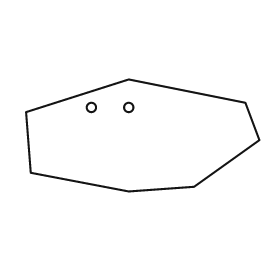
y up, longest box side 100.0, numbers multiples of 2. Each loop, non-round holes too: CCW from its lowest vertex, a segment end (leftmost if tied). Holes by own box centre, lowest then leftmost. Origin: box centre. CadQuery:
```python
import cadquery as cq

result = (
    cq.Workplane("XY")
    .moveTo(-6.0, -24.0)
    .lineTo(22.0, -22.0)
    .lineTo(50.0, -2.0)
    .lineTo(44.0, 14.0)
    .lineTo(-6.0, 24.0)
    .lineTo(-50.0, 10.0)
    .lineTo(-48.0, -16.0)
    .close()
    .moveTo(-22.0, 12.0)
    .circle(2.0)
    .moveTo(-6.0, 12.0)
    .circle(2.0)
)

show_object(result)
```